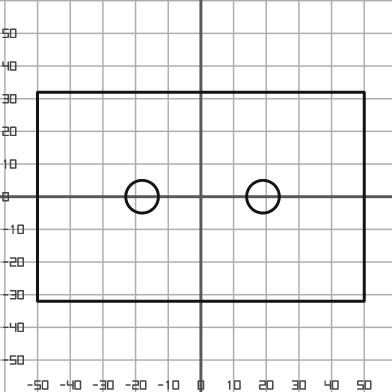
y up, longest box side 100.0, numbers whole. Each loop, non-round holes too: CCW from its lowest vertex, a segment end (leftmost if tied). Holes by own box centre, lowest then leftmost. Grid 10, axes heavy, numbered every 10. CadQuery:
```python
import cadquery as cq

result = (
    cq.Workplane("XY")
    .moveTo(-50.0, -32.0)
    .lineTo(50.0, -32.0)
    .lineTo(50.0, 32.0)
    .lineTo(-50.0, 32.0)
    .close()
    .moveTo(-18.0, 0.0)
    .circle(5.0)
    .moveTo(19.0, 0.0)
    .circle(5.0)
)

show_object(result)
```